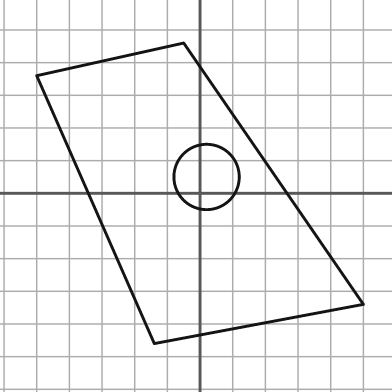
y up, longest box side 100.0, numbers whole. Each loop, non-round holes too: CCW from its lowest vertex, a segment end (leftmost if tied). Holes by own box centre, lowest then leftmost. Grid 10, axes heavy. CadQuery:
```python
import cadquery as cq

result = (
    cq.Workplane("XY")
    .moveTo(-14.0, -46.0)
    .lineTo(50.0, -34.0)
    .lineTo(-5.0, 46.0)
    .lineTo(-50.0, 36.0)
    .close()
    .moveTo(2.0, 5.0)
    .circle(10.0)
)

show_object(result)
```